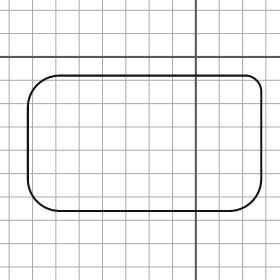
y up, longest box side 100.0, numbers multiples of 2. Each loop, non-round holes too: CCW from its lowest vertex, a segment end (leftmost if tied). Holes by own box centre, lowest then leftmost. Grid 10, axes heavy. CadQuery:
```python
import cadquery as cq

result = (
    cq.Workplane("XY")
    .moveTo(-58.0, -66.0)
    .lineTo(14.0, -66.0)
    .threePointArc((24.0, -62.0), (28.0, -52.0))
    .lineTo(28.0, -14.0)
    .threePointArc((26.0, -10.0), (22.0, -8.0))
    .lineTo(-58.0, -8.0)
    .threePointArc((-68.0, -12.0), (-72.0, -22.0))
    .lineTo(-72.0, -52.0)
    .threePointArc((-68.0, -62.0), (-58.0, -66.0))
    .close()
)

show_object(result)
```